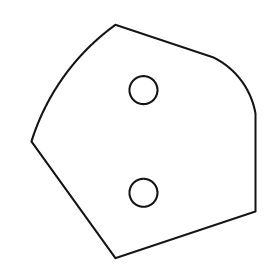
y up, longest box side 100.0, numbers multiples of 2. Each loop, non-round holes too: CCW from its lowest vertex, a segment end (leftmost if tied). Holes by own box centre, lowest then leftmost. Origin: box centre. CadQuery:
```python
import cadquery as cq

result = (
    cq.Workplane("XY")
    .moveTo(-12.0, -50.0)
    .lineTo(48.0, -30.0)
    .lineTo(48.0, 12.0)
    .threePointArc((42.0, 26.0), (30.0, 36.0))
    .lineTo(-12.0, 50.0)
    .threePointArc((-34.0, 28.0), (-48.0, 0.0))
    .close()
    .moveTo(0.0, -22.0)
    .circle(6.0)
    .moveTo(0.0, 22.0)
    .circle(6.0)
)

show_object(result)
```